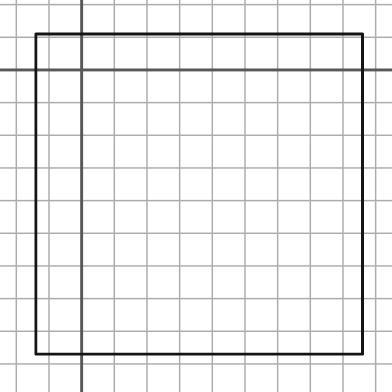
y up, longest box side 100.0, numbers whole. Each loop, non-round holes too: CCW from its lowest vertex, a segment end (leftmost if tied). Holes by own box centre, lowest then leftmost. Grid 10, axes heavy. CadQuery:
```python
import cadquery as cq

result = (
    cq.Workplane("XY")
    .moveTo(-14.0, -87.0)
    .lineTo(86.0, -87.0)
    .lineTo(86.0, 11.0)
    .lineTo(-14.0, 11.0)
    .close()
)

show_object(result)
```